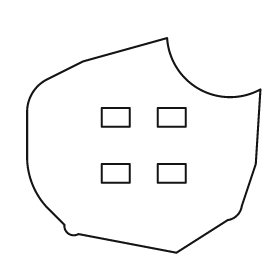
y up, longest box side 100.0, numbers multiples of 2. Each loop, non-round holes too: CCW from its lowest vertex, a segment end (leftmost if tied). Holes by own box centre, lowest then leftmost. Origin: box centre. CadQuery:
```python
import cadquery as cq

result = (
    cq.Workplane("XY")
    .moveTo(14.0, -46.0)
    .lineTo(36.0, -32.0)
    .threePointArc((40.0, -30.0), (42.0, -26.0))
    .lineTo(48.0, -8.0)
    .lineTo(50.0, 24.0)
    .threePointArc((24.0, 24.0), (10.0, 46.0))
    .lineTo(-26.0, 36.0)
    .lineTo(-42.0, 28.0)
    .threePointArc((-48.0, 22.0), (-50.0, 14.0))
    .lineTo(-50.0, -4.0)
    .threePointArc((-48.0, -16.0), (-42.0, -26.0))
    .lineTo(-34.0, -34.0)
    .threePointArc((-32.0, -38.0), (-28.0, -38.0))
    .close()
    .moveTo(-18.0, -16.0)
    .lineTo(-6.0, -16.0)
    .lineTo(-6.0, -8.0)
    .lineTo(-18.0, -8.0)
    .close()
    .moveTo(6.0, -16.0)
    .lineTo(18.0, -16.0)
    .lineTo(18.0, -8.0)
    .lineTo(6.0, -8.0)
    .close()
    .moveTo(-18.0, 8.0)
    .lineTo(-6.0, 8.0)
    .lineTo(-6.0, 16.0)
    .lineTo(-18.0, 16.0)
    .close()
    .moveTo(6.0, 8.0)
    .lineTo(18.0, 8.0)
    .lineTo(18.0, 16.0)
    .lineTo(6.0, 16.0)
    .close()
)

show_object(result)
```